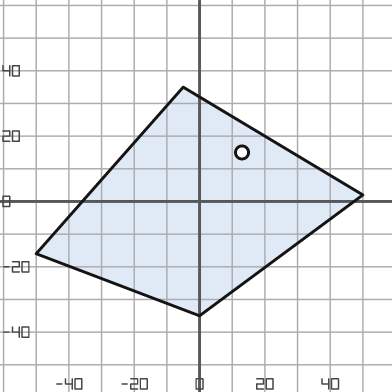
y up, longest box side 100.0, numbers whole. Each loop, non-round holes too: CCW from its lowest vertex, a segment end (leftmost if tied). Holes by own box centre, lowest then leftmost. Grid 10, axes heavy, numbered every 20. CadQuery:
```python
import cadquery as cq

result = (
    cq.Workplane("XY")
    .moveTo(0.0, -35.0)
    .lineTo(50.0, 2.0)
    .lineTo(-5.0, 35.0)
    .lineTo(-50.0, -16.0)
    .close()
    .moveTo(13.0, 15.0)
    .circle(2.0)
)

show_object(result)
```